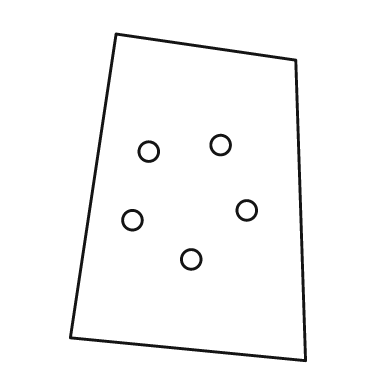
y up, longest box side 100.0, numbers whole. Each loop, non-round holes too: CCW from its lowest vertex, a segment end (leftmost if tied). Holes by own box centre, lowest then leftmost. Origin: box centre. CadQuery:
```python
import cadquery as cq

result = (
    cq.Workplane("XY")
    .moveTo(36.0, -50.0)
    .lineTo(33.0, 42.0)
    .lineTo(-22.0, 50.0)
    .lineTo(-36.0, -43.0)
    .close()
    .moveTo(1.0, -19.0)
    .circle(3.0)
    .moveTo(-17.0, -7.0)
    .circle(3.0)
    .moveTo(18.0, -4.0)
    .circle(3.0)
    .moveTo(-12.0, 14.0)
    .circle(3.0)
    .moveTo(10.0, 16.0)
    .circle(3.0)
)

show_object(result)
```